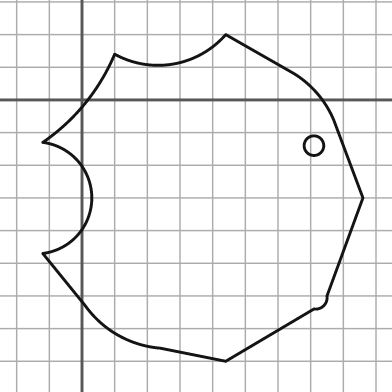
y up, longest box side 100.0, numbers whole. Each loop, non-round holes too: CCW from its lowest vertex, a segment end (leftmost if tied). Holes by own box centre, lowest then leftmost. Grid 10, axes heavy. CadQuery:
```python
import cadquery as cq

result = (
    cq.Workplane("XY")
    .moveTo(44.0, -80.0)
    .lineTo(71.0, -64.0)
    .threePointArc((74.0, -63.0), (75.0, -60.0))
    .lineTo(86.0, -30.0)
    .lineTo(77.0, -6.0)
    .threePointArc((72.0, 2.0), (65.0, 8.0))
    .lineTo(44.0, 20.0)
    .threePointArc((28.0, 11.0), (10.0, 14.0))
    .threePointArc((1.0, -1.0), (-12.0, -13.0))
    .threePointArc((3.0, -30.0), (-12.0, -47.0))
    .lineTo(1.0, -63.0)
    .threePointArc((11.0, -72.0), (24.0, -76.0))
    .close()
    .moveTo(71.0, -14.0)
    .circle(3.0)
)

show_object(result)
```